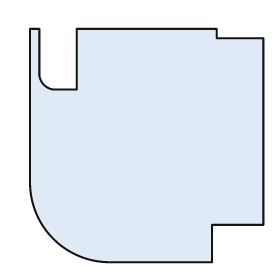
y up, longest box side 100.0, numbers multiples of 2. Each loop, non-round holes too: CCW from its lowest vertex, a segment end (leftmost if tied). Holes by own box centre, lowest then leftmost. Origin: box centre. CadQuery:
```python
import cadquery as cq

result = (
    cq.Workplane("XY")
    .moveTo(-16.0, -50.0)
    .lineTo(28.0, -50.0)
    .lineTo(28.0, -34.0)
    .lineTo(50.0, -34.0)
    .lineTo(50.0, 46.0)
    .lineTo(30.0, 46.0)
    .lineTo(30.0, 50.0)
    .lineTo(-30.0, 50.0)
    .lineTo(-30.0, 24.0)
    .lineTo(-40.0, 24.0)
    .threePointArc((-44.0, 26.0), (-46.0, 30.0))
    .lineTo(-46.0, 50.0)
    .lineTo(-50.0, 50.0)
    .lineTo(-50.0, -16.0)
    .threePointArc((-40.0, -40.0), (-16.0, -50.0))
    .close()
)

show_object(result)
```